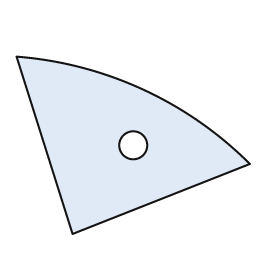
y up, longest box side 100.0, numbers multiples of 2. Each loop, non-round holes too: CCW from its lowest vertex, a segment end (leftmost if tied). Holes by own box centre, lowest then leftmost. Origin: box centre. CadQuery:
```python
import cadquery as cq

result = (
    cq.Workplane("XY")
    .moveTo(-26.0, -38.0)
    .lineTo(50.0, -8.0)
    .threePointArc((4.0, 24.0), (-50.0, 38.0))
    .close()
    .moveTo(0.0, 0.0)
    .circle(6.0)
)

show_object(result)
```